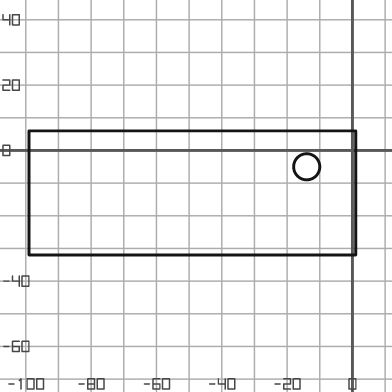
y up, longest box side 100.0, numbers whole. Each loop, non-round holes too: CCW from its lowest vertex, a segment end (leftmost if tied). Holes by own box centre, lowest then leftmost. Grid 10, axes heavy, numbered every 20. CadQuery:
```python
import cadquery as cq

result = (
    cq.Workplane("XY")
    .moveTo(-99.0, -32.0)
    .lineTo(1.0, -32.0)
    .lineTo(1.0, 6.0)
    .lineTo(-99.0, 6.0)
    .close()
    .moveTo(-14.0, -5.0)
    .circle(4.0)
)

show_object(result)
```